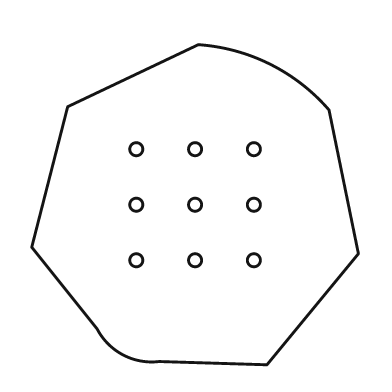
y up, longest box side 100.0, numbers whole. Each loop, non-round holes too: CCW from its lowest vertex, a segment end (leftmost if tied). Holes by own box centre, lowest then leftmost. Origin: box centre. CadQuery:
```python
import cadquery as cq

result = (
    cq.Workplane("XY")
    .moveTo(22.0, -49.0)
    .lineTo(50.0, -15.0)
    .lineTo(41.0, 29.0)
    .threePointArc((23.0, 43.0), (1.0, 49.0))
    .lineTo(-39.0, 30.0)
    .lineTo(-50.0, -13.0)
    .lineTo(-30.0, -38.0)
    .threePointArc((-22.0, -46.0), (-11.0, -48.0))
    .close()
    .moveTo(-18.0, -17.0)
    .circle(2.0)
    .moveTo(0.0, -17.0)
    .circle(2.0)
    .moveTo(18.0, -17.0)
    .circle(2.0)
    .moveTo(-18.0, 0.0)
    .circle(2.0)
    .moveTo(0.0, 0.0)
    .circle(2.0)
    .moveTo(18.0, 0.0)
    .circle(2.0)
    .moveTo(-18.0, 17.0)
    .circle(2.0)
    .moveTo(0.0, 17.0)
    .circle(2.0)
    .moveTo(18.0, 17.0)
    .circle(2.0)
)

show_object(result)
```